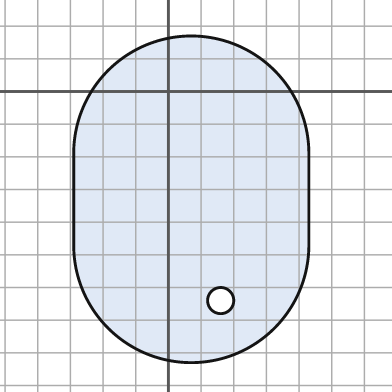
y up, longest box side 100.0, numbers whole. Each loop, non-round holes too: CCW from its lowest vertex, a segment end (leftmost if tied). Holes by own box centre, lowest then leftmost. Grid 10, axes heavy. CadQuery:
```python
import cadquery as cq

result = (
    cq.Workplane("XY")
    .moveTo(-29.0, -47.0)
    .threePointArc((7.0, -83.0), (43.0, -47.0))
    .lineTo(43.0, -19.0)
    .threePointArc((7.0, 17.0), (-29.0, -19.0))
    .close()
    .moveTo(16.0, -64.0)
    .circle(4.0)
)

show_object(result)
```